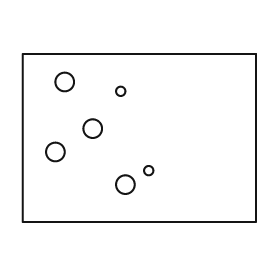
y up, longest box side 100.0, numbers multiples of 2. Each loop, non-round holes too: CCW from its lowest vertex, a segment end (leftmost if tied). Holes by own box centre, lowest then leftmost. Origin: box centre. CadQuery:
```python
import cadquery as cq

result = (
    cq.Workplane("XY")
    .moveTo(-50.0, -36.0)
    .lineTo(50.0, -36.0)
    .lineTo(50.0, 36.0)
    .lineTo(-50.0, 36.0)
    .close()
    .moveTo(-6.0, -20.0)
    .circle(4.0)
    .moveTo(4.0, -14.0)
    .circle(2.0)
    .moveTo(-36.0, -6.0)
    .circle(4.0)
    .moveTo(-20.0, 4.0)
    .circle(4.0)
    .moveTo(-8.0, 20.0)
    .circle(2.0)
    .moveTo(-32.0, 24.0)
    .circle(4.0)
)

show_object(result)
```